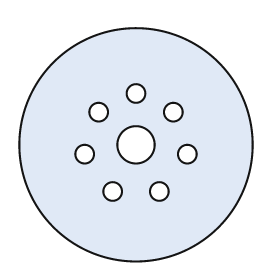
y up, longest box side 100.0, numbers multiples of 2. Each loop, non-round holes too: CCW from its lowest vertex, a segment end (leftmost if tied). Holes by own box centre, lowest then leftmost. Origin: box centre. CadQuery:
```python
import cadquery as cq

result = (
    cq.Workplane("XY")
    .moveTo(0.0, 0.0)
    .circle(50.0)
    .moveTo(-10.0, -20.0)
    .circle(4.0)
    .moveTo(10.0, -20.0)
    .circle(4.0)
    .moveTo(-22.0, -4.0)
    .circle(4.0)
    .moveTo(22.0, -4.0)
    .circle(4.0)
    .moveTo(0.0, 0.0)
    .circle(8.0)
    .moveTo(-16.0, 14.0)
    .circle(4.0)
    .moveTo(16.0, 14.0)
    .circle(4.0)
    .moveTo(0.0, 22.0)
    .circle(4.0)
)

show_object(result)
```